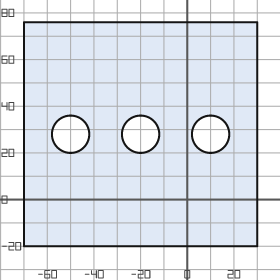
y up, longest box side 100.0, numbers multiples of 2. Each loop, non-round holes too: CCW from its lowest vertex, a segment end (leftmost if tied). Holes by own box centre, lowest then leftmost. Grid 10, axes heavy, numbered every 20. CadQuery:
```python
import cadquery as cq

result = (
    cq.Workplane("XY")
    .moveTo(-70.0, -20.0)
    .lineTo(30.0, -20.0)
    .lineTo(30.0, 76.0)
    .lineTo(-70.0, 76.0)
    .close()
    .moveTo(-50.0, 28.0)
    .circle(8.0)
    .moveTo(-20.0, 28.0)
    .circle(8.0)
    .moveTo(10.0, 28.0)
    .circle(8.0)
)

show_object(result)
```